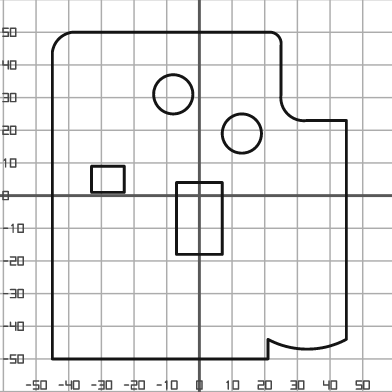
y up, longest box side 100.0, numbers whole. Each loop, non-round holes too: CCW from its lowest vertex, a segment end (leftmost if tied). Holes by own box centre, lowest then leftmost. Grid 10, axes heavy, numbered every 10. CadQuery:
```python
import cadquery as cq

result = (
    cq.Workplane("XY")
    .moveTo(-45.0, -50.0)
    .lineTo(21.0, -50.0)
    .lineTo(21.0, -44.0)
    .threePointArc((33.0, -47.0), (45.0, -44.0))
    .lineTo(45.0, 23.0)
    .lineTo(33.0, 23.0)
    .threePointArc((27.0, 25.0), (25.0, 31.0))
    .lineTo(25.0, 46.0)
    .threePointArc((24.0, 49.0), (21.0, 50.0))
    .lineTo(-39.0, 50.0)
    .threePointArc((-43.0, 48.0), (-45.0, 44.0))
    .close()
    .moveTo(-7.0, -18.0)
    .lineTo(7.0, -18.0)
    .lineTo(7.0, 4.0)
    .lineTo(-7.0, 4.0)
    .close()
    .moveTo(-33.0, 1.0)
    .lineTo(-23.0, 1.0)
    .lineTo(-23.0, 9.0)
    .lineTo(-33.0, 9.0)
    .close()
    .moveTo(13.0, 19.0)
    .circle(6.0)
    .moveTo(-8.0, 31.0)
    .circle(6.0)
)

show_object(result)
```